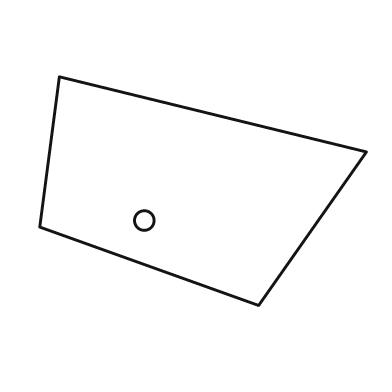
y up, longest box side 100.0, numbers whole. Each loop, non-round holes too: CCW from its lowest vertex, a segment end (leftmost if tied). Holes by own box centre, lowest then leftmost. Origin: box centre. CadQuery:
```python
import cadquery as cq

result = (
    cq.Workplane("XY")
    .moveTo(17.0, -35.0)
    .lineTo(50.0, 12.0)
    .lineTo(-44.0, 35.0)
    .lineTo(-50.0, -11.0)
    .close()
    .moveTo(-18.0, -9.0)
    .circle(3.0)
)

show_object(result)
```